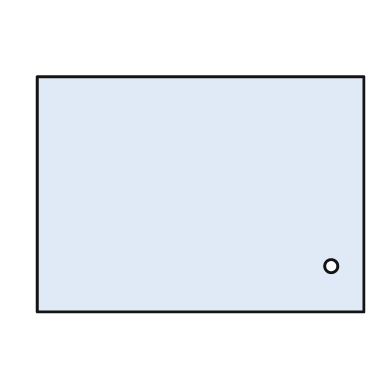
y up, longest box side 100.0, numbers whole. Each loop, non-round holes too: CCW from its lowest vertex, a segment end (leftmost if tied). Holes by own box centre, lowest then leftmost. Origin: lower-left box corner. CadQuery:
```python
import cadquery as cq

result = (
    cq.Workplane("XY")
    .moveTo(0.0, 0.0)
    .lineTo(100.0, 0.0)
    .lineTo(100.0, 72.0)
    .lineTo(0.0, 72.0)
    .close()
    .moveTo(90.0, 14.0)
    .circle(2.0)
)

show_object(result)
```